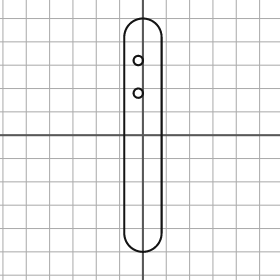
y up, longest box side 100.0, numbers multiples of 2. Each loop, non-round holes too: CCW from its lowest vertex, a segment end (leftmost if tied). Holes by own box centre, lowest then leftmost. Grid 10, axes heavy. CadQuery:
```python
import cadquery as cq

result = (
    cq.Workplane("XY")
    .moveTo(-8.0, -42.0)
    .threePointArc((0.0, -50.0), (8.0, -42.0))
    .lineTo(8.0, 42.0)
    .threePointArc((0.0, 50.0), (-8.0, 42.0))
    .close()
    .moveTo(-2.0, 18.0)
    .circle(2.0)
    .moveTo(-2.0, 32.0)
    .circle(2.0)
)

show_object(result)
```